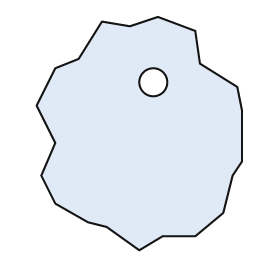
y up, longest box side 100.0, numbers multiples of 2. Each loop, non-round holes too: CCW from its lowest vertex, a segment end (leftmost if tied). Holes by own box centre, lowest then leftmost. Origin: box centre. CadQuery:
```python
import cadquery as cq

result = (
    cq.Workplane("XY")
    .moveTo(0.0, -50.0)
    .lineTo(10.0, -44.0)
    .lineTo(24.0, -44.0)
    .lineTo(36.0, -34.0)
    .lineTo(40.0, -18.0)
    .lineTo(44.0, -12.0)
    .lineTo(44.0, 10.0)
    .lineTo(42.0, 20.0)
    .lineTo(26.0, 30.0)
    .lineTo(24.0, 44.0)
    .lineTo(8.0, 50.0)
    .lineTo(-4.0, 46.0)
    .lineTo(-16.0, 48.0)
    .lineTo(-26.0, 32.0)
    .lineTo(-36.0, 28.0)
    .lineTo(-44.0, 12.0)
    .lineTo(-36.0, -4.0)
    .lineTo(-42.0, -18.0)
    .lineTo(-36.0, -30.0)
    .lineTo(-22.0, -38.0)
    .lineTo(-14.0, -40.0)
    .close()
    .moveTo(6.0, 22.0)
    .circle(6.0)
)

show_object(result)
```